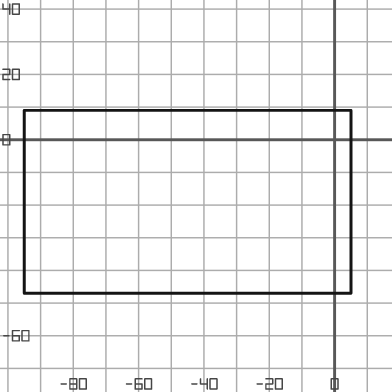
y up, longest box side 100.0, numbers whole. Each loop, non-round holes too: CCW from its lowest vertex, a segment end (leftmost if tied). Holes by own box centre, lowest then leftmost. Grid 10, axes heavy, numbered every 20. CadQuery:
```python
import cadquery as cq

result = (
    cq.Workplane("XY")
    .moveTo(-95.0, -47.0)
    .lineTo(5.0, -47.0)
    .lineTo(5.0, 9.0)
    .lineTo(-95.0, 9.0)
    .close()
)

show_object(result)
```